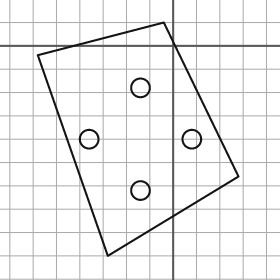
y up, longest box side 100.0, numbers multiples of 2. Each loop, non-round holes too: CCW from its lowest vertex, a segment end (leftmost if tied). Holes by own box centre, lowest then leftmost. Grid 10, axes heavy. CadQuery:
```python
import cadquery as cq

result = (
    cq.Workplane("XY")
    .moveTo(-28.0, -90.0)
    .lineTo(28.0, -56.0)
    .lineTo(-4.0, 10.0)
    .lineTo(-58.0, -4.0)
    .close()
    .moveTo(-14.0, -62.0)
    .circle(4.0)
    .moveTo(-36.0, -40.0)
    .circle(4.0)
    .moveTo(8.0, -40.0)
    .circle(4.0)
    .moveTo(-14.0, -18.0)
    .circle(4.0)
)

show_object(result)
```